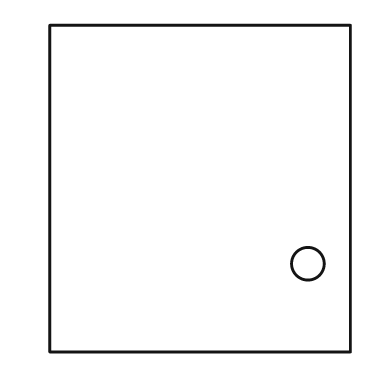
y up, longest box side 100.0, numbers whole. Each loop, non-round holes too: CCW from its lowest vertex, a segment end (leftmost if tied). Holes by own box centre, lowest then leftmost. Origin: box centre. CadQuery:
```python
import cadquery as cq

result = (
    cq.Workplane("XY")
    .moveTo(-46.0, -50.0)
    .lineTo(46.0, -50.0)
    .lineTo(46.0, 50.0)
    .lineTo(-46.0, 50.0)
    .close()
    .moveTo(33.0, -23.0)
    .circle(5.0)
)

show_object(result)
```